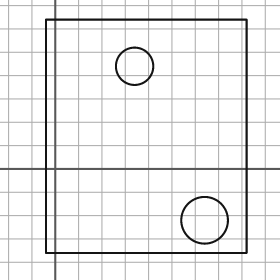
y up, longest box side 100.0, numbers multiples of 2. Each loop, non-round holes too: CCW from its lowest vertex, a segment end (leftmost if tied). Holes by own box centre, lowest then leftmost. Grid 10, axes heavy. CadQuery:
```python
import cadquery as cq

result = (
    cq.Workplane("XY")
    .moveTo(-4.0, -36.0)
    .lineTo(82.0, -36.0)
    .lineTo(82.0, 64.0)
    .lineTo(-4.0, 64.0)
    .close()
    .moveTo(64.0, -22.0)
    .circle(10.0)
    .moveTo(34.0, 44.0)
    .circle(8.0)
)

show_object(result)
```